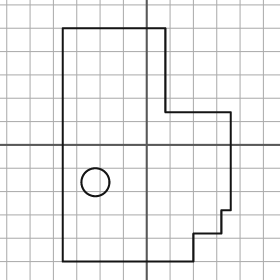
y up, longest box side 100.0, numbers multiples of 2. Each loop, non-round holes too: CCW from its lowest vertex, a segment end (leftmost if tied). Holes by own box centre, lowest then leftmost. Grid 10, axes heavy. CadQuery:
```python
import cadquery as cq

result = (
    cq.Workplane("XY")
    .moveTo(-36.0, -50.0)
    .lineTo(20.0, -50.0)
    .lineTo(20.0, -38.0)
    .lineTo(32.0, -38.0)
    .lineTo(32.0, -28.0)
    .lineTo(36.0, -28.0)
    .lineTo(36.0, 14.0)
    .lineTo(8.0, 14.0)
    .lineTo(8.0, 50.0)
    .lineTo(-36.0, 50.0)
    .close()
    .moveTo(-22.0, -16.0)
    .circle(6.0)
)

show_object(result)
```